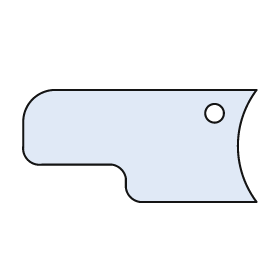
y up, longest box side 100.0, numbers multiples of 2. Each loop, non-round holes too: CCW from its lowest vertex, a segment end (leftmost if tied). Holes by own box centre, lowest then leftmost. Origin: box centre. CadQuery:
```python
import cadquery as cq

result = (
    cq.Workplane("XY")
    .moveTo(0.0, -24.0)
    .lineTo(50.0, -24.0)
    .threePointArc((42.0, 0.0), (50.0, 24.0))
    .lineTo(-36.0, 24.0)
    .threePointArc((-46.0, 20.0), (-50.0, 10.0))
    .lineTo(-50.0, 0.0)
    .threePointArc((-48.0, -6.0), (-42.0, -8.0))
    .lineTo(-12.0, -8.0)
    .threePointArc((-8.0, -10.0), (-6.0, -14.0))
    .lineTo(-6.0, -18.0)
    .threePointArc((-4.0, -22.0), (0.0, -24.0))
    .close()
    .moveTo(32.0, 14.0)
    .circle(4.0)
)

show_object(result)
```